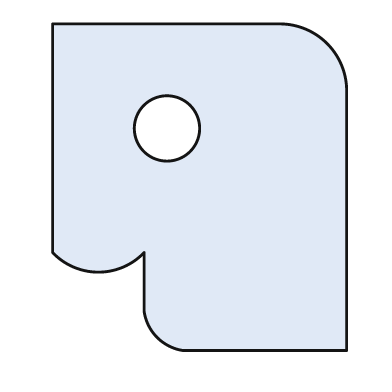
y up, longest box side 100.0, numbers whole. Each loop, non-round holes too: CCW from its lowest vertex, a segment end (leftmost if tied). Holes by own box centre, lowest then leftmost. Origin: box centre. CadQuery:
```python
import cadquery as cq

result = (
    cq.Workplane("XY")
    .moveTo(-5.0, -50.0)
    .lineTo(45.0, -50.0)
    .lineTo(45.0, 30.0)
    .threePointArc((39.0, 44.0), (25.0, 50.0))
    .lineTo(-45.0, 50.0)
    .lineTo(-45.0, -20.0)
    .threePointArc((-31.0, -26.0), (-17.0, -20.0))
    .lineTo(-17.0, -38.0)
    .threePointArc((-13.0, -46.0), (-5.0, -50.0))
    .close()
    .moveTo(-10.0, 18.0)
    .circle(10.0)
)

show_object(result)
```